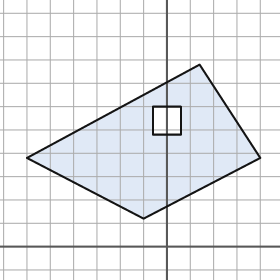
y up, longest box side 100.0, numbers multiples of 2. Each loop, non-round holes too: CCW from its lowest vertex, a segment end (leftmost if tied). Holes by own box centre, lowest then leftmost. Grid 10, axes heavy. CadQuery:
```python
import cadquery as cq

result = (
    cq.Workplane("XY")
    .moveTo(-10.0, 12.0)
    .lineTo(40.0, 38.0)
    .lineTo(14.0, 78.0)
    .lineTo(-60.0, 38.0)
    .close()
    .moveTo(-6.0, 48.0)
    .lineTo(6.0, 48.0)
    .lineTo(6.0, 60.0)
    .lineTo(-6.0, 60.0)
    .close()
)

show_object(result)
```